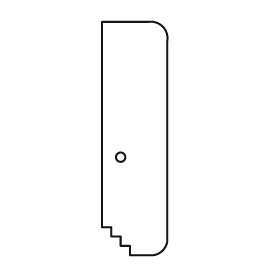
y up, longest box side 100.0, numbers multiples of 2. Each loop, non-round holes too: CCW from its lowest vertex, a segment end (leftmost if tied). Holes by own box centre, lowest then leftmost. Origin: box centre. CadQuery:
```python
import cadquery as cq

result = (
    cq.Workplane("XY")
    .moveTo(-2.0, -50.0)
    .lineTo(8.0, -50.0)
    .threePointArc((12.0, -48.0), (14.0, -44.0))
    .lineTo(14.0, 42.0)
    .threePointArc((12.0, 48.0), (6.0, 50.0))
    .lineTo(-14.0, 50.0)
    .lineTo(-14.0, -38.0)
    .lineTo(-10.0, -38.0)
    .lineTo(-10.0, -42.0)
    .lineTo(-6.0, -42.0)
    .lineTo(-6.0, -46.0)
    .lineTo(-2.0, -46.0)
    .close()
    .moveTo(-6.0, -8.0)
    .circle(2.0)
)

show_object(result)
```